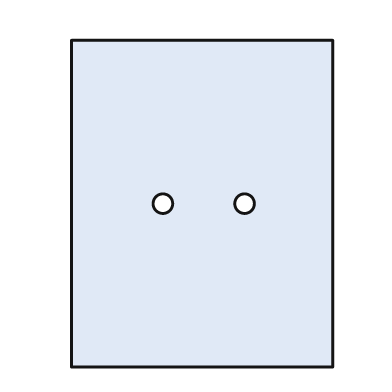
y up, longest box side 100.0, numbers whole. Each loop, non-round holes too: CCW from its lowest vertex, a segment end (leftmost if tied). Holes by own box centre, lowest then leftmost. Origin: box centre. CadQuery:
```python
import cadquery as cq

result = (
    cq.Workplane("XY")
    .moveTo(-40.0, -50.0)
    .lineTo(40.0, -50.0)
    .lineTo(40.0, 50.0)
    .lineTo(-40.0, 50.0)
    .close()
    .moveTo(-12.0, 0.0)
    .circle(3.0)
    .moveTo(13.0, 0.0)
    .circle(3.0)
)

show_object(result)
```